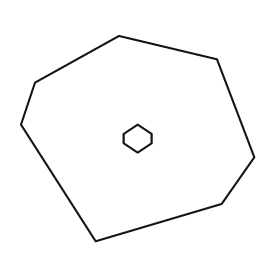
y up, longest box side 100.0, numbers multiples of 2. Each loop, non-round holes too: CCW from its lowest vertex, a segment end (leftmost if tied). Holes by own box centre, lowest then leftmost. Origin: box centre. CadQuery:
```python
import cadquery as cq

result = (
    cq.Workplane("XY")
    .moveTo(-18.0, -44.0)
    .lineTo(36.0, -28.0)
    .lineTo(50.0, -8.0)
    .lineTo(34.0, 34.0)
    .lineTo(-8.0, 44.0)
    .lineTo(-44.0, 24.0)
    .lineTo(-50.0, 6.0)
    .close()
    .moveTo(0.0, -6.0)
    .lineTo(6.0, -2.0)
    .lineTo(6.0, 2.0)
    .lineTo(0.0, 6.0)
    .lineTo(-6.0, 2.0)
    .lineTo(-6.0, -2.0)
    .close()
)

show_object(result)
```